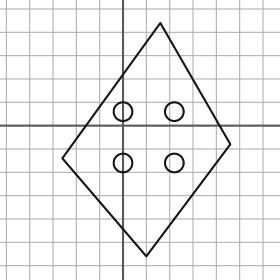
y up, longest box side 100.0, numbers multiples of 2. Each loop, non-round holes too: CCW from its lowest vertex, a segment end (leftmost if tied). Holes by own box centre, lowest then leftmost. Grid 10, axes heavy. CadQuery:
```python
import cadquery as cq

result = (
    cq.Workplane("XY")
    .moveTo(10.0, -56.0)
    .lineTo(46.0, -8.0)
    .lineTo(16.0, 44.0)
    .lineTo(-26.0, -14.0)
    .close()
    .moveTo(0.0, -16.0)
    .circle(4.0)
    .moveTo(22.0, -16.0)
    .circle(4.0)
    .moveTo(0.0, 6.0)
    .circle(4.0)
    .moveTo(22.0, 6.0)
    .circle(4.0)
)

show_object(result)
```